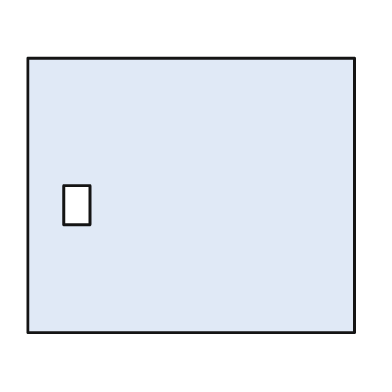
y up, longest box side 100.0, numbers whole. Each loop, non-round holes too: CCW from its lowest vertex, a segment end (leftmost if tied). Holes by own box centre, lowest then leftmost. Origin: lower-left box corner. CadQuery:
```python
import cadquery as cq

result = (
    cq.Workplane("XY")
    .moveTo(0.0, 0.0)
    .lineTo(100.0, 0.0)
    .lineTo(100.0, 84.0)
    .lineTo(0.0, 84.0)
    .close()
    .moveTo(11.0, 33.0)
    .lineTo(19.0, 33.0)
    .lineTo(19.0, 45.0)
    .lineTo(11.0, 45.0)
    .close()
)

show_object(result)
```